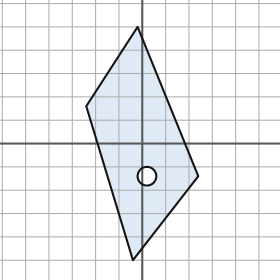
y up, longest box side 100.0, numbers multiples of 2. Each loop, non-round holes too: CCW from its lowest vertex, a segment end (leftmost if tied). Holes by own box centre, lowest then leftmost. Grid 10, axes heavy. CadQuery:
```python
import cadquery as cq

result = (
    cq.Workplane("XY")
    .moveTo(-4.0, -50.0)
    .lineTo(24.0, -14.0)
    .lineTo(-2.0, 50.0)
    .lineTo(-24.0, 16.0)
    .close()
    .moveTo(2.0, -14.0)
    .circle(4.0)
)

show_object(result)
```